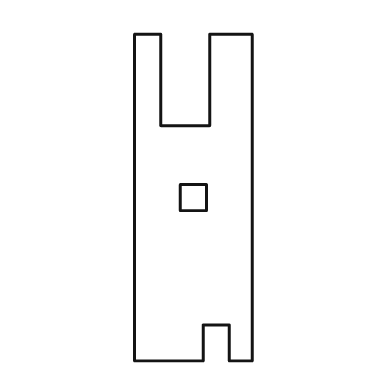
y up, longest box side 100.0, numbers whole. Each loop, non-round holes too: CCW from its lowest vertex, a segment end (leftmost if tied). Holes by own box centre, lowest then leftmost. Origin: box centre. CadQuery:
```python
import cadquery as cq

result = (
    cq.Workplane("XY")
    .moveTo(-18.0, -50.0)
    .lineTo(3.0, -50.0)
    .lineTo(3.0, -39.0)
    .lineTo(11.0, -39.0)
    .lineTo(11.0, -50.0)
    .lineTo(18.0, -50.0)
    .lineTo(18.0, 50.0)
    .lineTo(5.0, 50.0)
    .lineTo(5.0, 22.0)
    .lineTo(-10.0, 22.0)
    .lineTo(-10.0, 50.0)
    .lineTo(-18.0, 50.0)
    .close()
    .moveTo(-4.0, -4.0)
    .lineTo(4.0, -4.0)
    .lineTo(4.0, 4.0)
    .lineTo(-4.0, 4.0)
    .close()
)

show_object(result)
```